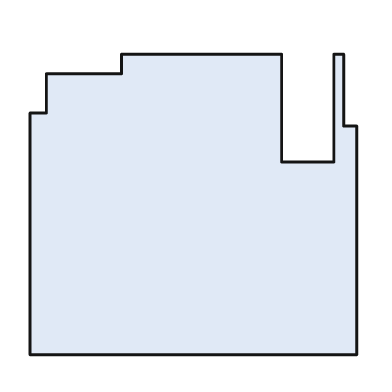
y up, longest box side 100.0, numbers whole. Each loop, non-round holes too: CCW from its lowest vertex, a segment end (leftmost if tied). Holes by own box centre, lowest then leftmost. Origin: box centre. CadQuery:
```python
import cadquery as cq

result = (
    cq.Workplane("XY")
    .moveTo(-50.0, -46.0)
    .lineTo(50.0, -46.0)
    .lineTo(50.0, 24.0)
    .lineTo(46.0, 24.0)
    .lineTo(46.0, 46.0)
    .lineTo(43.0, 46.0)
    .lineTo(43.0, 13.0)
    .lineTo(27.0, 13.0)
    .lineTo(27.0, 46.0)
    .lineTo(-22.0, 46.0)
    .lineTo(-22.0, 40.0)
    .lineTo(-45.0, 40.0)
    .lineTo(-45.0, 28.0)
    .lineTo(-50.0, 28.0)
    .close()
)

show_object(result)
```